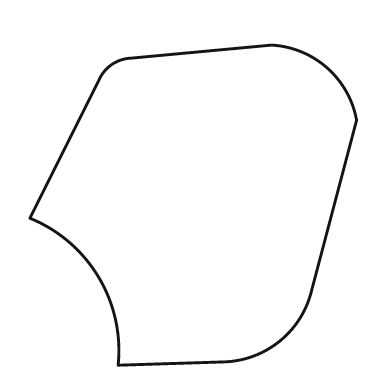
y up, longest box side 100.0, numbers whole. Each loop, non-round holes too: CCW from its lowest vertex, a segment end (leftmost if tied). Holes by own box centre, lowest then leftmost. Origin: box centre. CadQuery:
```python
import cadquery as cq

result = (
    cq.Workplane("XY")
    .moveTo(-23.0, -49.0)
    .lineTo(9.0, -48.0)
    .threePointArc((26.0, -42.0), (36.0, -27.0))
    .lineTo(50.0, 26.0)
    .threePointArc((41.0, 42.0), (24.0, 49.0))
    .lineTo(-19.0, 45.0)
    .threePointArc((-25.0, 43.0), (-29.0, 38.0))
    .lineTo(-50.0, -4.0)
    .threePointArc((-29.0, -22.0), (-23.0, -49.0))
    .close()
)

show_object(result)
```